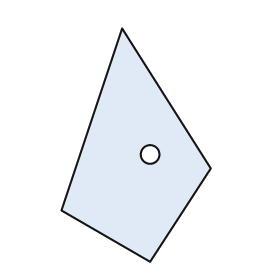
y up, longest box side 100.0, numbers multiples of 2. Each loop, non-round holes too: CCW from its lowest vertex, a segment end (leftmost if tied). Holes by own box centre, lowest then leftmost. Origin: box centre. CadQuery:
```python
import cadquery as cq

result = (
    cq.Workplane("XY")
    .moveTo(6.0, -50.0)
    .lineTo(32.0, -10.0)
    .lineTo(-6.0, 50.0)
    .lineTo(-32.0, -28.0)
    .close()
    .moveTo(6.0, -4.0)
    .circle(4.0)
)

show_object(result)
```